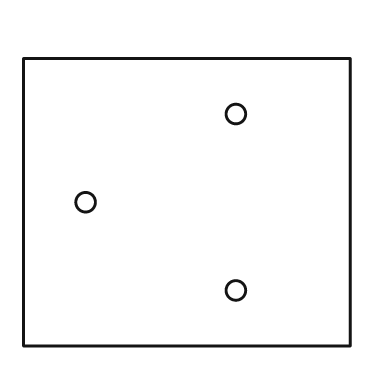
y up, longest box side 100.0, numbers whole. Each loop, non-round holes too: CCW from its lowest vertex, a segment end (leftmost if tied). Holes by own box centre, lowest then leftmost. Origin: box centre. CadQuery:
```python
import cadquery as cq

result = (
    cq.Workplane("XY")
    .moveTo(-50.0, -44.0)
    .lineTo(50.0, -44.0)
    .lineTo(50.0, 44.0)
    .lineTo(-50.0, 44.0)
    .close()
    .moveTo(15.0, -27.0)
    .circle(3.0)
    .moveTo(-31.0, 0.0)
    .circle(3.0)
    .moveTo(15.0, 27.0)
    .circle(3.0)
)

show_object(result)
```